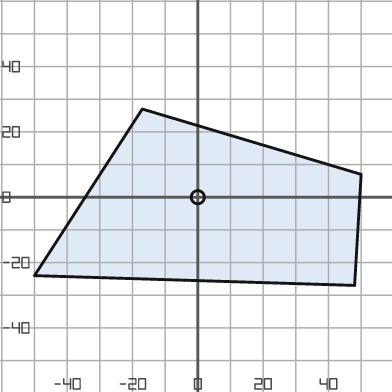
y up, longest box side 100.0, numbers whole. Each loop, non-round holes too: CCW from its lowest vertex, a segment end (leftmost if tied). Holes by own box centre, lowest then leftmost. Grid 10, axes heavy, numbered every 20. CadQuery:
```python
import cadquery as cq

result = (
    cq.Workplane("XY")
    .moveTo(48.0, -27.0)
    .lineTo(50.0, 7.0)
    .lineTo(-17.0, 27.0)
    .lineTo(-50.0, -24.0)
    .close()
    .moveTo(0.0, 0.0)
    .circle(2.0)
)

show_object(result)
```